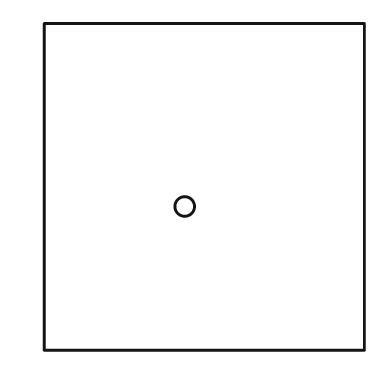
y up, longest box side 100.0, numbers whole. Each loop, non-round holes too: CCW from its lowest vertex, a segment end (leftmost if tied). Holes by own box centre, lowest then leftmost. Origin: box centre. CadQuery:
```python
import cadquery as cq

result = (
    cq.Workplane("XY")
    .moveTo(-49.0, -50.0)
    .lineTo(49.0, -50.0)
    .lineTo(49.0, 50.0)
    .lineTo(-49.0, 50.0)
    .close()
    .moveTo(-6.0, -6.0)
    .circle(3.0)
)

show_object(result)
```